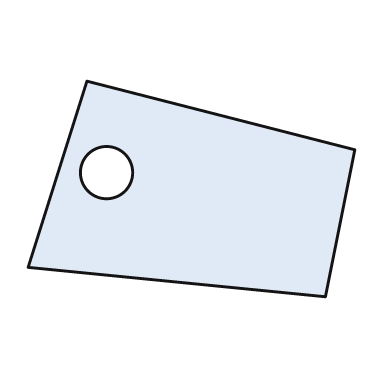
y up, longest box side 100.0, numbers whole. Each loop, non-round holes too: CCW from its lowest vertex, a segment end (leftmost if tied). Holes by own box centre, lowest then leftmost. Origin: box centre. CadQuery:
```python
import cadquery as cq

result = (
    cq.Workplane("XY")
    .moveTo(41.0, -33.0)
    .lineTo(50.0, 12.0)
    .lineTo(-32.0, 33.0)
    .lineTo(-50.0, -24.0)
    .close()
    .moveTo(-26.0, 5.0)
    .circle(8.0)
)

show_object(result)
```